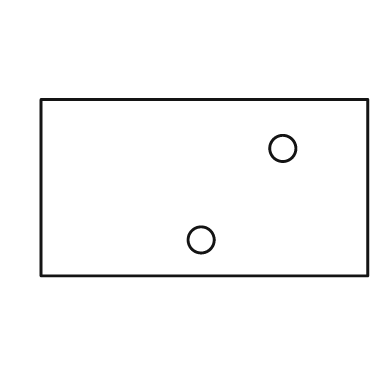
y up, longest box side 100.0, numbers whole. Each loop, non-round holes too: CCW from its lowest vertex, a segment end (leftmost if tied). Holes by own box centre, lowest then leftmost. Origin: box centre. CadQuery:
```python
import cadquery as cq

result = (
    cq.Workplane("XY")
    .moveTo(-50.0, -27.0)
    .lineTo(50.0, -27.0)
    .lineTo(50.0, 27.0)
    .lineTo(-50.0, 27.0)
    .close()
    .moveTo(-1.0, -16.0)
    .circle(4.0)
    .moveTo(24.0, 12.0)
    .circle(4.0)
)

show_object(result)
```